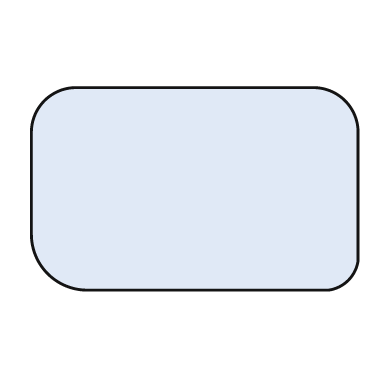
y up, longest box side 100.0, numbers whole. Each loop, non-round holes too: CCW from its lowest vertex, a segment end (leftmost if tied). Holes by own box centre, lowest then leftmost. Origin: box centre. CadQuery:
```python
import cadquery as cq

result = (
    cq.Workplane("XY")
    .moveTo(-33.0, -31.0)
    .lineTo(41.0, -31.0)
    .threePointArc((47.0, -28.0), (50.0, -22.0))
    .lineTo(50.0, 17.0)
    .threePointArc((46.0, 27.0), (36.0, 31.0))
    .lineTo(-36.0, 31.0)
    .threePointArc((-46.0, 27.0), (-50.0, 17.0))
    .lineTo(-50.0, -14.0)
    .threePointArc((-45.0, -26.0), (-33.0, -31.0))
    .close()
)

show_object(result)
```